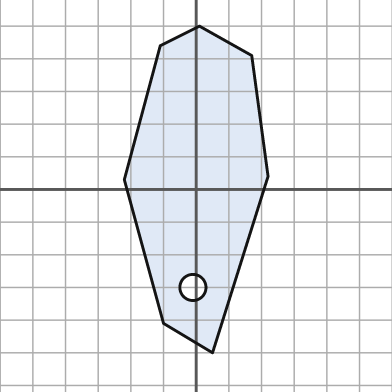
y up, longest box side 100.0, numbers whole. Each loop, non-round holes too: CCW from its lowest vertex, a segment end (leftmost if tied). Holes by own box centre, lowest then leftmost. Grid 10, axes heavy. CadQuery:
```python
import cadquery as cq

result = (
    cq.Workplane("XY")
    .moveTo(5.0, -50.0)
    .lineTo(22.0, 4.0)
    .lineTo(17.0, 41.0)
    .lineTo(1.0, 50.0)
    .lineTo(-11.0, 44.0)
    .lineTo(-22.0, 3.0)
    .lineTo(-10.0, -41.0)
    .close()
    .moveTo(-1.0, -30.0)
    .circle(4.0)
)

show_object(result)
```